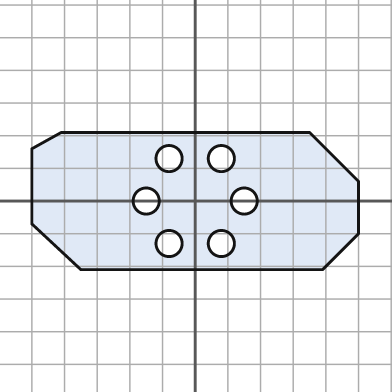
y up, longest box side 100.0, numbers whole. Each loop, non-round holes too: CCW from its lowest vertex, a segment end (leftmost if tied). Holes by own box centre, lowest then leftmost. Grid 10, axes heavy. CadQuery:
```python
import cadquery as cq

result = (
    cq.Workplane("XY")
    .moveTo(-35.0, -21.0)
    .lineTo(39.0, -21.0)
    .lineTo(50.0, -10.0)
    .lineTo(50.0, 6.0)
    .lineTo(35.0, 21.0)
    .lineTo(-41.0, 21.0)
    .lineTo(-50.0, 16.0)
    .lineTo(-50.0, -7.0)
    .close()
    .moveTo(-8.0, -13.0)
    .circle(4.0)
    .moveTo(8.0, -13.0)
    .circle(4.0)
    .moveTo(-15.0, 0.0)
    .circle(4.0)
    .moveTo(15.0, 0.0)
    .circle(4.0)
    .moveTo(-8.0, 13.0)
    .circle(4.0)
    .moveTo(8.0, 13.0)
    .circle(4.0)
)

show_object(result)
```